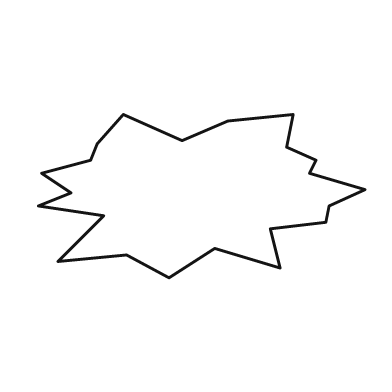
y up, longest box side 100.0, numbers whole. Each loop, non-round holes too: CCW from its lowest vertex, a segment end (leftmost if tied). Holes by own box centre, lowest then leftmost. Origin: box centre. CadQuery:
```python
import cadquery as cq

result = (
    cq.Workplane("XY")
    .moveTo(-10.0, -25.0)
    .lineTo(4.0, -16.0)
    .lineTo(24.0, -22.0)
    .lineTo(21.0, -10.0)
    .lineTo(38.0, -8.0)
    .lineTo(39.0, -3.0)
    .lineTo(50.0, 2.0)
    .lineTo(33.0, 7.0)
    .lineTo(35.0, 11.0)
    .lineTo(26.0, 15.0)
    .lineTo(28.0, 25.0)
    .lineTo(8.0, 23.0)
    .lineTo(-6.0, 17.0)
    .lineTo(-24.0, 25.0)
    .lineTo(-32.0, 16.0)
    .lineTo(-34.0, 11.0)
    .lineTo(-49.0, 7.0)
    .lineTo(-40.0, 1.0)
    .lineTo(-50.0, -3.0)
    .lineTo(-30.0, -6.0)
    .lineTo(-44.0, -20.0)
    .lineTo(-23.0, -18.0)
    .close()
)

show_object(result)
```